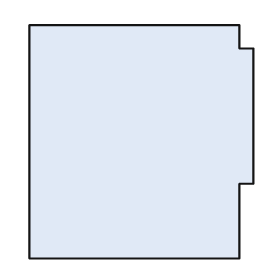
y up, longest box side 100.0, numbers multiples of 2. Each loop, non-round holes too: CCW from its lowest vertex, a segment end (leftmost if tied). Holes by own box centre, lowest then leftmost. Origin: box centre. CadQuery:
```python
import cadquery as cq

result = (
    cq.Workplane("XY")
    .moveTo(-48.0, -50.0)
    .lineTo(42.0, -50.0)
    .lineTo(42.0, -18.0)
    .lineTo(48.0, -18.0)
    .lineTo(48.0, 40.0)
    .lineTo(42.0, 40.0)
    .lineTo(42.0, 50.0)
    .lineTo(-48.0, 50.0)
    .close()
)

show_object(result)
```